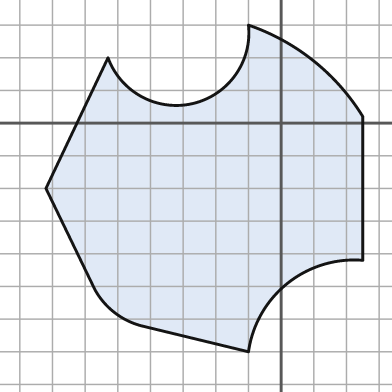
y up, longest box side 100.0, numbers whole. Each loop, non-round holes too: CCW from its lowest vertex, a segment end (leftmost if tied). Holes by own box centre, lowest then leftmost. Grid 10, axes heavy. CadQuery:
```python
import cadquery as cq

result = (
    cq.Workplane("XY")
    .moveTo(-10.0, -70.0)
    .threePointArc((2.0, -49.0), (25.0, -42.0))
    .lineTo(25.0, 2.0)
    .threePointArc((10.0, 19.0), (-10.0, 30.0))
    .threePointArc((-27.0, 6.0), (-53.0, 20.0))
    .lineTo(-72.0, -20.0)
    .lineTo(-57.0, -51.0)
    .threePointArc((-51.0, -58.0), (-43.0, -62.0))
    .close()
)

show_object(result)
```